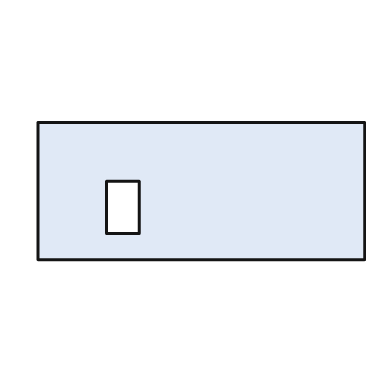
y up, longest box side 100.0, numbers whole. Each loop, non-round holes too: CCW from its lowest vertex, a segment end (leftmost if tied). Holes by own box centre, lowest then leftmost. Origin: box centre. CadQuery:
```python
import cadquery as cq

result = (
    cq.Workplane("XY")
    .moveTo(-50.0, -21.0)
    .lineTo(50.0, -21.0)
    .lineTo(50.0, 21.0)
    .lineTo(-50.0, 21.0)
    .close()
    .moveTo(-29.0, -13.0)
    .lineTo(-19.0, -13.0)
    .lineTo(-19.0, 3.0)
    .lineTo(-29.0, 3.0)
    .close()
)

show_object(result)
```